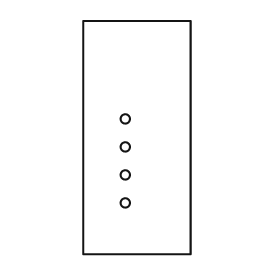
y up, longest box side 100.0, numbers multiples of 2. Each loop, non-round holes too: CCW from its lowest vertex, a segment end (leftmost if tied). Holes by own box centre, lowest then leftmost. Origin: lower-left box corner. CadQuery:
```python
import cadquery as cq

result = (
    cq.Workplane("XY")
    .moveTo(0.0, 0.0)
    .lineTo(46.0, 0.0)
    .lineTo(46.0, 100.0)
    .lineTo(0.0, 100.0)
    .close()
    .moveTo(18.0, 22.0)
    .circle(2.0)
    .moveTo(18.0, 34.0)
    .circle(2.0)
    .moveTo(18.0, 46.0)
    .circle(2.0)
    .moveTo(18.0, 58.0)
    .circle(2.0)
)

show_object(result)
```